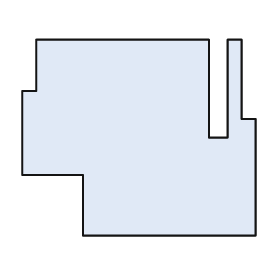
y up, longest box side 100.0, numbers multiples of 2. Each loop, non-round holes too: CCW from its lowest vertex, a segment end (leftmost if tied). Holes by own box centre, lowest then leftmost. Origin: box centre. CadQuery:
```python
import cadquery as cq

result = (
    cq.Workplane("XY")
    .moveTo(-24.0, -42.0)
    .lineTo(50.0, -42.0)
    .lineTo(50.0, 8.0)
    .lineTo(44.0, 8.0)
    .lineTo(44.0, 42.0)
    .lineTo(38.0, 42.0)
    .lineTo(38.0, 0.0)
    .lineTo(30.0, 0.0)
    .lineTo(30.0, 42.0)
    .lineTo(-44.0, 42.0)
    .lineTo(-44.0, 20.0)
    .lineTo(-50.0, 20.0)
    .lineTo(-50.0, -16.0)
    .lineTo(-24.0, -16.0)
    .close()
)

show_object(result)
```